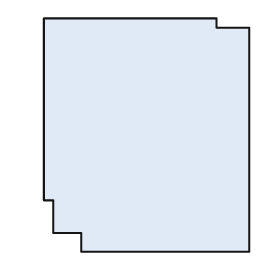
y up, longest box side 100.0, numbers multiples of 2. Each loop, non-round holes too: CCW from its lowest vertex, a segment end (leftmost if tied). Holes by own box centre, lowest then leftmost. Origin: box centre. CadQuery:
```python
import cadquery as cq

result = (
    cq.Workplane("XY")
    .moveTo(-28.0, -50.0)
    .lineTo(44.0, -50.0)
    .lineTo(44.0, 46.0)
    .lineTo(30.0, 46.0)
    .lineTo(30.0, 50.0)
    .lineTo(-44.0, 50.0)
    .lineTo(-44.0, -28.0)
    .lineTo(-40.0, -28.0)
    .lineTo(-40.0, -42.0)
    .lineTo(-28.0, -42.0)
    .close()
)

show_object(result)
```